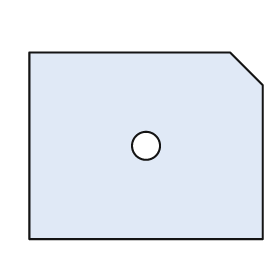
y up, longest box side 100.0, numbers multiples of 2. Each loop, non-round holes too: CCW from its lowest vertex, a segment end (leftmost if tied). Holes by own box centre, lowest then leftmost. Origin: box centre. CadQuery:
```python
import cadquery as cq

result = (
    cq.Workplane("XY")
    .moveTo(-50.0, -40.0)
    .lineTo(50.0, -40.0)
    .lineTo(50.0, 26.0)
    .lineTo(36.0, 40.0)
    .lineTo(-50.0, 40.0)
    .close()
    .moveTo(0.0, 0.0)
    .circle(6.0)
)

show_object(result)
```